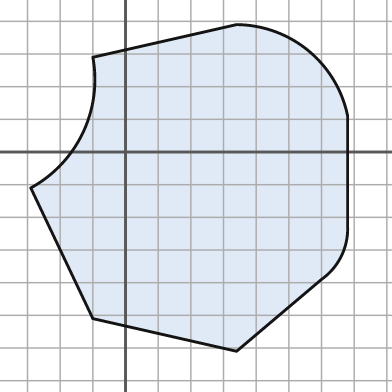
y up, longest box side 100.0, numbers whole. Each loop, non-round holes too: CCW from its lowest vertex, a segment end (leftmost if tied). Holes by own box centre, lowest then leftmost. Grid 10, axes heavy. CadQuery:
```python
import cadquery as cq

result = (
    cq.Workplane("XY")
    .moveTo(34.0, -61.0)
    .lineTo(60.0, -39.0)
    .threePointArc((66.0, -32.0), (68.0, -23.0))
    .lineTo(68.0, 11.0)
    .threePointArc((56.0, 31.0), (34.0, 39.0))
    .lineTo(-10.0, 29.0)
    .threePointArc((-13.0, 6.0), (-29.0, -11.0))
    .lineTo(-10.0, -51.0)
    .close()
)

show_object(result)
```